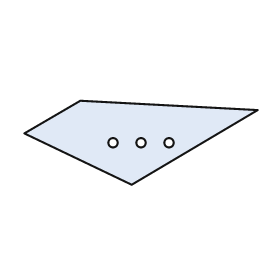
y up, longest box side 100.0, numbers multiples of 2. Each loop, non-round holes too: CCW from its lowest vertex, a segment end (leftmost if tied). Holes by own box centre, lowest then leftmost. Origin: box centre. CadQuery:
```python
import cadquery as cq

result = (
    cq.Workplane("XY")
    .moveTo(-4.0, -18.0)
    .lineTo(50.0, 14.0)
    .lineTo(-26.0, 18.0)
    .lineTo(-50.0, 4.0)
    .close()
    .moveTo(-12.0, 0.0)
    .circle(2.0)
    .moveTo(0.0, 0.0)
    .circle(2.0)
    .moveTo(12.0, 0.0)
    .circle(2.0)
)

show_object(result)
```